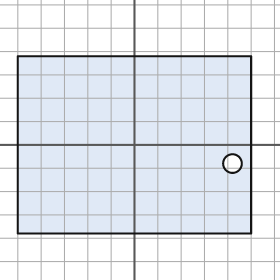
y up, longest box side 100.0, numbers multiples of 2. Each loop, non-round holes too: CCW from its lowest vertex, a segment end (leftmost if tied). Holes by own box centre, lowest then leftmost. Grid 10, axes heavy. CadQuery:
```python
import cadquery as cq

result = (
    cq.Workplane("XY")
    .moveTo(-50.0, -38.0)
    .lineTo(50.0, -38.0)
    .lineTo(50.0, 38.0)
    .lineTo(-50.0, 38.0)
    .close()
    .moveTo(42.0, -8.0)
    .circle(4.0)
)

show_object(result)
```